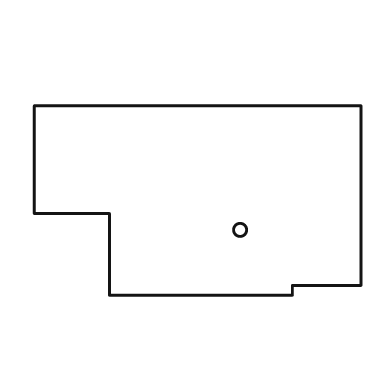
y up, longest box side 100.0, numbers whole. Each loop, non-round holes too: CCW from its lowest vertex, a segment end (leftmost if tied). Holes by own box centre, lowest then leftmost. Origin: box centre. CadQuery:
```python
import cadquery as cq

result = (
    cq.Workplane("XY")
    .moveTo(-27.0, -29.0)
    .lineTo(29.0, -29.0)
    .lineTo(29.0, -26.0)
    .lineTo(50.0, -26.0)
    .lineTo(50.0, 29.0)
    .lineTo(-50.0, 29.0)
    .lineTo(-50.0, -4.0)
    .lineTo(-27.0, -4.0)
    .close()
    .moveTo(13.0, -9.0)
    .circle(2.0)
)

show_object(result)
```